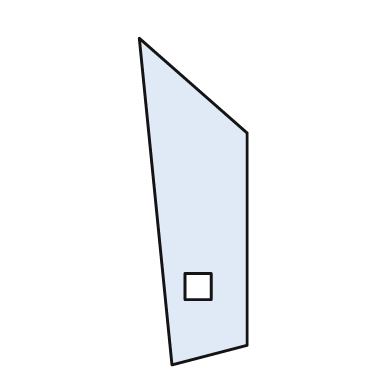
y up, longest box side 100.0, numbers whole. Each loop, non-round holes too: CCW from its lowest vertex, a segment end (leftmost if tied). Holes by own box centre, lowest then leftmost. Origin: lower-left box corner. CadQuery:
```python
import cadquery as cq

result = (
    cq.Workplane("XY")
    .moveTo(10.0, 0.0)
    .lineTo(33.0, 6.0)
    .lineTo(33.0, 71.0)
    .lineTo(0.0, 100.0)
    .close()
    .moveTo(14.0, 20.0)
    .lineTo(22.0, 20.0)
    .lineTo(22.0, 28.0)
    .lineTo(14.0, 28.0)
    .close()
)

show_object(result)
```